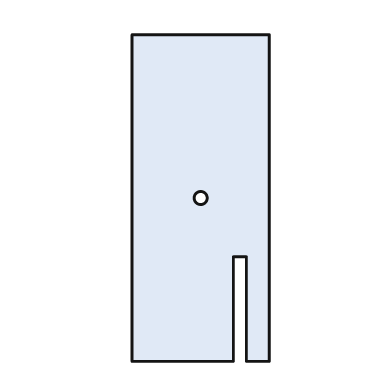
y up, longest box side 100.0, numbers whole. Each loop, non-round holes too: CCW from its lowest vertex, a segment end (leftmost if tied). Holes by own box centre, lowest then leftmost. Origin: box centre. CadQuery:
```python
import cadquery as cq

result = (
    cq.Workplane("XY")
    .moveTo(-21.0, -50.0)
    .lineTo(10.0, -50.0)
    .lineTo(10.0, -18.0)
    .lineTo(14.0, -18.0)
    .lineTo(14.0, -50.0)
    .lineTo(21.0, -50.0)
    .lineTo(21.0, 50.0)
    .lineTo(-21.0, 50.0)
    .close()
    .moveTo(0.0, 0.0)
    .circle(2.0)
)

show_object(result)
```